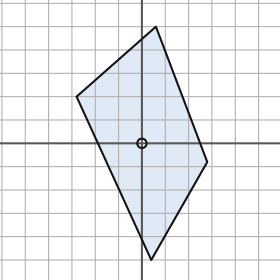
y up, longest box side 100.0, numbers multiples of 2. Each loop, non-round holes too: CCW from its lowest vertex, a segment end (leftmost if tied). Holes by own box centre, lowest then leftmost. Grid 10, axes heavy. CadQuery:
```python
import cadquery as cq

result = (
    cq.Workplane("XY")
    .moveTo(4.0, -50.0)
    .lineTo(28.0, -8.0)
    .lineTo(6.0, 50.0)
    .lineTo(-28.0, 20.0)
    .close()
    .moveTo(0.0, 0.0)
    .circle(2.0)
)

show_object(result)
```